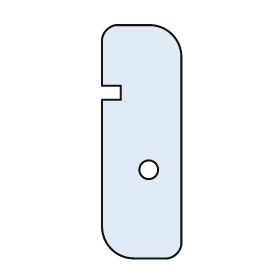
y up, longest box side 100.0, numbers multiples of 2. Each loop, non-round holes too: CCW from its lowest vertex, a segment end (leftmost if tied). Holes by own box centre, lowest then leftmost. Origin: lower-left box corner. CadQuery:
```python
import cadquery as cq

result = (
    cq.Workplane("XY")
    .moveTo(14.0, 0.0)
    .lineTo(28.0, 0.0)
    .threePointArc((32.0, 2.0), (34.0, 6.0))
    .lineTo(34.0, 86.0)
    .threePointArc((30.0, 96.0), (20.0, 100.0))
    .lineTo(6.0, 100.0)
    .threePointArc((2.0, 98.0), (0.0, 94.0))
    .lineTo(0.0, 74.0)
    .lineTo(8.0, 74.0)
    .lineTo(8.0, 68.0)
    .lineTo(0.0, 68.0)
    .lineTo(0.0, 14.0)
    .threePointArc((4.0, 4.0), (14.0, 0.0))
    .close()
    .moveTo(20.0, 38.0)
    .circle(4.0)
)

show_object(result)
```